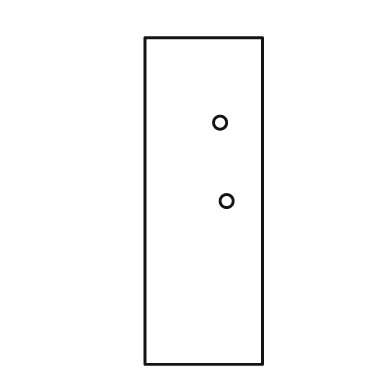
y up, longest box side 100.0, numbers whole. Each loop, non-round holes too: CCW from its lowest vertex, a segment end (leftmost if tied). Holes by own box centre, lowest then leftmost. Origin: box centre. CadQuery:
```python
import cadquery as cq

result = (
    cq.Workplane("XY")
    .moveTo(-18.0, -50.0)
    .lineTo(18.0, -50.0)
    .lineTo(18.0, 50.0)
    .lineTo(-18.0, 50.0)
    .close()
    .moveTo(7.0, 0.0)
    .circle(2.0)
    .moveTo(5.0, 24.0)
    .circle(2.0)
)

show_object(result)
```